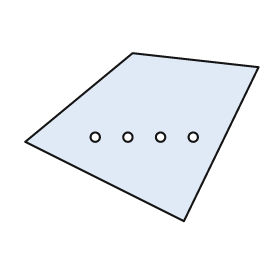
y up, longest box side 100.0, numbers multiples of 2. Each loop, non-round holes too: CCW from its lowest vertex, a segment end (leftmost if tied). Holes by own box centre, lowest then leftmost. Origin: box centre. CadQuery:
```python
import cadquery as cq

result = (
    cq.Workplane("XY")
    .moveTo(18.0, -36.0)
    .lineTo(50.0, 30.0)
    .lineTo(-4.0, 36.0)
    .lineTo(-50.0, -2.0)
    .close()
    .moveTo(-20.0, 0.0)
    .circle(2.0)
    .moveTo(-6.0, 0.0)
    .circle(2.0)
    .moveTo(8.0, 0.0)
    .circle(2.0)
    .moveTo(22.0, 0.0)
    .circle(2.0)
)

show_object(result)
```